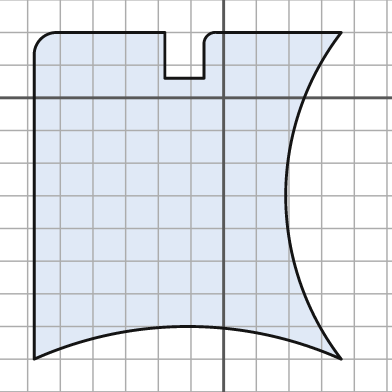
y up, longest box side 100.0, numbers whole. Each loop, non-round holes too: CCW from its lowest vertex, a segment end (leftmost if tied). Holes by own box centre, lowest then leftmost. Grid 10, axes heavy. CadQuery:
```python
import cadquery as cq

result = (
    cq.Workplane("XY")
    .moveTo(-58.0, -80.0)
    .threePointArc((-11.0, -70.0), (36.0, -80.0))
    .threePointArc((19.0, -30.0), (36.0, 20.0))
    .lineTo(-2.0, 20.0)
    .threePointArc((-5.0, 19.0), (-6.0, 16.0))
    .lineTo(-6.0, 6.0)
    .lineTo(-18.0, 6.0)
    .lineTo(-18.0, 20.0)
    .lineTo(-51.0, 20.0)
    .threePointArc((-56.0, 18.0), (-58.0, 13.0))
    .close()
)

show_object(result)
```